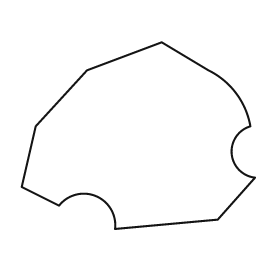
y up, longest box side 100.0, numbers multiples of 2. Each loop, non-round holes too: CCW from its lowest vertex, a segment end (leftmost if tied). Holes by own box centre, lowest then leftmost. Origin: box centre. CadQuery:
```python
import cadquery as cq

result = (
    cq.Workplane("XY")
    .moveTo(-10.0, -40.0)
    .lineTo(34.0, -36.0)
    .lineTo(50.0, -18.0)
    .threePointArc((40.0, -8.0), (48.0, 4.0))
    .threePointArc((42.0, 18.0), (30.0, 28.0))
    .lineTo(10.0, 40.0)
    .lineTo(-22.0, 28.0)
    .lineTo(-44.0, 4.0)
    .lineTo(-50.0, -22.0)
    .lineTo(-34.0, -30.0)
    .threePointArc((-18.0, -26.0), (-10.0, -40.0))
    .close()
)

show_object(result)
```